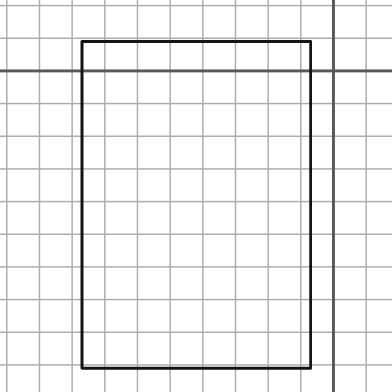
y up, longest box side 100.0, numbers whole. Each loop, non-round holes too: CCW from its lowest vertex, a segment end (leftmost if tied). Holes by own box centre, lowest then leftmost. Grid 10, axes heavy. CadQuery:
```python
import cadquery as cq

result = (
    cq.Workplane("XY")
    .moveTo(-77.0, -91.0)
    .lineTo(-7.0, -91.0)
    .lineTo(-7.0, 9.0)
    .lineTo(-77.0, 9.0)
    .close()
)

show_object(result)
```